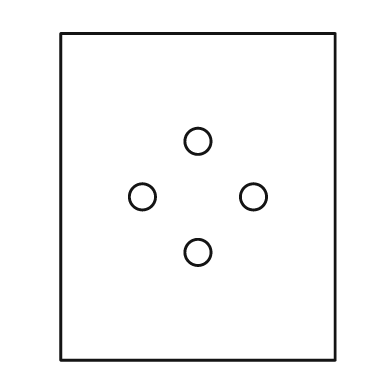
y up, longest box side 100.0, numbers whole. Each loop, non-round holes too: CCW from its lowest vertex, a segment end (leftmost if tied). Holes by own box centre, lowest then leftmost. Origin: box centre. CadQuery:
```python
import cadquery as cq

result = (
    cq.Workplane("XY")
    .moveTo(-42.0, -50.0)
    .lineTo(42.0, -50.0)
    .lineTo(42.0, 50.0)
    .lineTo(-42.0, 50.0)
    .close()
    .moveTo(0.0, -17.0)
    .circle(4.0)
    .moveTo(-17.0, 0.0)
    .circle(4.0)
    .moveTo(17.0, 0.0)
    .circle(4.0)
    .moveTo(0.0, 17.0)
    .circle(4.0)
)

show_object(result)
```